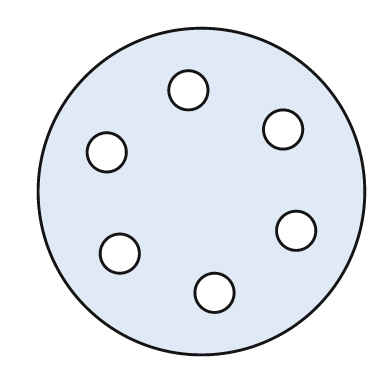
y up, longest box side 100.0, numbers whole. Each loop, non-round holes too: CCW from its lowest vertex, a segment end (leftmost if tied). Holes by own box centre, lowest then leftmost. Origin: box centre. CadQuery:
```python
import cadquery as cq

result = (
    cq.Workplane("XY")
    .moveTo(0.0, 0.0)
    .circle(50.0)
    .moveTo(4.0, -31.0)
    .circle(6.0)
    .moveTo(-25.0, -19.0)
    .circle(6.0)
    .moveTo(29.0, -12.0)
    .circle(6.0)
    .moveTo(-29.0, 12.0)
    .circle(6.0)
    .moveTo(25.0, 19.0)
    .circle(6.0)
    .moveTo(-4.0, 31.0)
    .circle(6.0)
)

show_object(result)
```